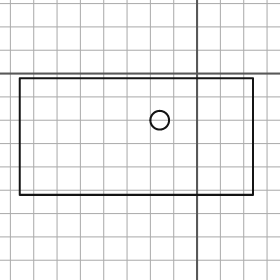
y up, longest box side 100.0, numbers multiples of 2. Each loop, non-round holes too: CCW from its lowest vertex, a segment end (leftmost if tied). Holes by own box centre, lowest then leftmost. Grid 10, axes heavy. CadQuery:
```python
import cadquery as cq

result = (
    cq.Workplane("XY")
    .moveTo(-76.0, -52.0)
    .lineTo(24.0, -52.0)
    .lineTo(24.0, -2.0)
    .lineTo(-76.0, -2.0)
    .close()
    .moveTo(-16.0, -20.0)
    .circle(4.0)
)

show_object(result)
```